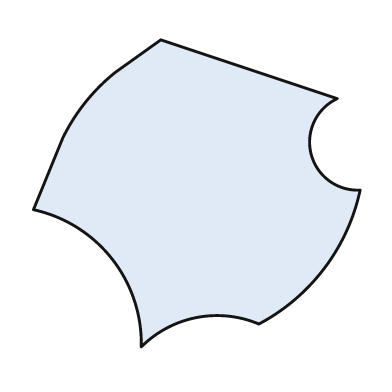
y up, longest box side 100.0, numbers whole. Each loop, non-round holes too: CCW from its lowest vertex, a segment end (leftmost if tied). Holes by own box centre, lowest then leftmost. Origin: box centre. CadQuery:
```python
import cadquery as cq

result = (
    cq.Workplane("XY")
    .moveTo(-17.0, -47.0)
    .threePointArc((0.0, -38.0), (19.0, -40.0))
    .threePointArc((39.0, -23.0), (50.0, 1.0))
    .threePointArc((35.0, 12.0), (43.0, 29.0))
    .lineTo(-11.0, 47.0)
    .lineTo(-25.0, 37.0)
    .threePointArc((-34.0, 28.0), (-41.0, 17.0))
    .lineTo(-50.0, -5.0)
    .threePointArc((-26.0, -20.0), (-17.0, -47.0))
    .close()
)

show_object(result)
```